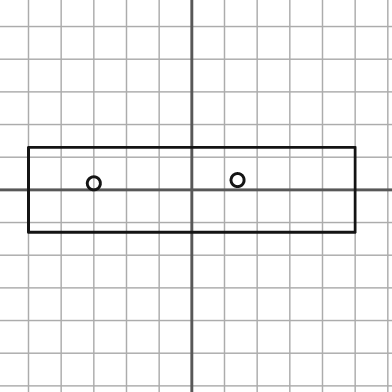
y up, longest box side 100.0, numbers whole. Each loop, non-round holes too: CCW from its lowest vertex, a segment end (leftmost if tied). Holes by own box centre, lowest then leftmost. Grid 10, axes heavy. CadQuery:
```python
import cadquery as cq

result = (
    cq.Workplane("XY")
    .moveTo(-50.0, -13.0)
    .lineTo(50.0, -13.0)
    .lineTo(50.0, 13.0)
    .lineTo(-50.0, 13.0)
    .close()
    .moveTo(-30.0, 2.0)
    .circle(2.0)
    .moveTo(14.0, 3.0)
    .circle(2.0)
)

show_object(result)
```